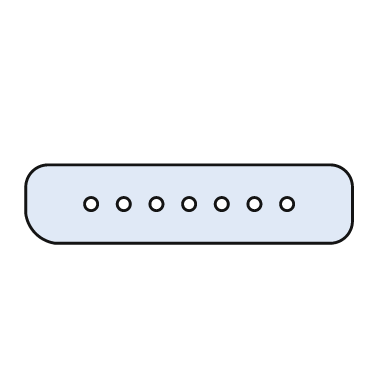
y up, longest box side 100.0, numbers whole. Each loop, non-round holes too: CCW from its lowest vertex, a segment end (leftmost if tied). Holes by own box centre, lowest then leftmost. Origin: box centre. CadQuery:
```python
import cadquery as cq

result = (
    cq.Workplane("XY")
    .moveTo(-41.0, -12.0)
    .lineTo(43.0, -12.0)
    .threePointArc((48.0, -10.0), (50.0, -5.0))
    .lineTo(50.0, 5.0)
    .threePointArc((48.0, 10.0), (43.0, 12.0))
    .lineTo(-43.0, 12.0)
    .threePointArc((-48.0, 10.0), (-50.0, 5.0))
    .lineTo(-50.0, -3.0)
    .threePointArc((-47.0, -9.0), (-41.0, -12.0))
    .close()
    .moveTo(-30.0, 0.0)
    .circle(2.0)
    .moveTo(-20.0, 0.0)
    .circle(2.0)
    .moveTo(-10.0, 0.0)
    .circle(2.0)
    .moveTo(0.0, 0.0)
    .circle(2.0)
    .moveTo(10.0, 0.0)
    .circle(2.0)
    .moveTo(20.0, 0.0)
    .circle(2.0)
    .moveTo(30.0, 0.0)
    .circle(2.0)
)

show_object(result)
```